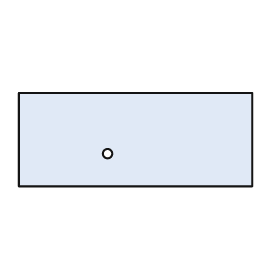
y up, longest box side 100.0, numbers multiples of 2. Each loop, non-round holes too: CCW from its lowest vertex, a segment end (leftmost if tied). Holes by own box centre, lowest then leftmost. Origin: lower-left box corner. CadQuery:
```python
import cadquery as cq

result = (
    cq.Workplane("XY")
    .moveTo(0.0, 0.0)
    .lineTo(100.0, 0.0)
    .lineTo(100.0, 40.0)
    .lineTo(0.0, 40.0)
    .close()
    .moveTo(38.0, 14.0)
    .circle(2.0)
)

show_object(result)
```